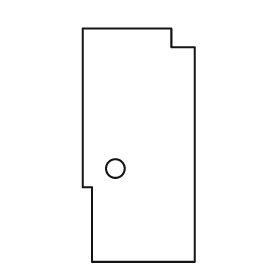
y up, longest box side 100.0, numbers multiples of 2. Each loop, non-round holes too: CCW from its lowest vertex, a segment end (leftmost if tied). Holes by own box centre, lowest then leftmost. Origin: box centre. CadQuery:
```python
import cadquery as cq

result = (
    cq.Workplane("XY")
    .moveTo(-20.0, -50.0)
    .lineTo(24.0, -50.0)
    .lineTo(24.0, 42.0)
    .lineTo(14.0, 42.0)
    .lineTo(14.0, 50.0)
    .lineTo(-24.0, 50.0)
    .lineTo(-24.0, -18.0)
    .lineTo(-20.0, -18.0)
    .close()
    .moveTo(-10.0, -10.0)
    .circle(4.0)
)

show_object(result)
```